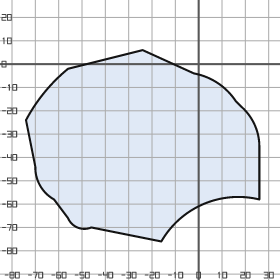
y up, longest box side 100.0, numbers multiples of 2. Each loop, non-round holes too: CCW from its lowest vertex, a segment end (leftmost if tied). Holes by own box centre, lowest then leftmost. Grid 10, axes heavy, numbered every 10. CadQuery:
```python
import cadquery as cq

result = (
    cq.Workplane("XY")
    .moveTo(-16.0, -76.0)
    .threePointArc((2.0, -60.0), (26.0, -58.0))
    .lineTo(26.0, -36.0)
    .threePointArc((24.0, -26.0), (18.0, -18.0))
    .lineTo(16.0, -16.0)
    .threePointArc((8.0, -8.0), (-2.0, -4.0))
    .lineTo(-24.0, 6.0)
    .lineTo(-56.0, -2.0)
    .threePointArc((-66.0, -12.0), (-74.0, -24.0))
    .lineTo(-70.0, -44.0)
    .threePointArc((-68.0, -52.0), (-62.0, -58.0))
    .lineTo(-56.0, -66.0)
    .threePointArc((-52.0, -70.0), (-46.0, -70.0))
    .close()
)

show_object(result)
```